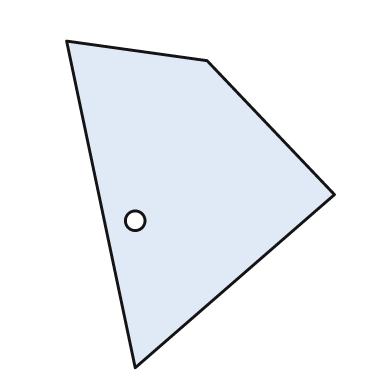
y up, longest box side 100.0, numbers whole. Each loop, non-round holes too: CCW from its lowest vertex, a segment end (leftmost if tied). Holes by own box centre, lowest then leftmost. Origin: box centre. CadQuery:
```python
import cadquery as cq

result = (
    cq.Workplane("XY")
    .moveTo(-20.0, -50.0)
    .lineTo(41.0, 3.0)
    .lineTo(2.0, 44.0)
    .lineTo(-41.0, 50.0)
    .close()
    .moveTo(-20.0, -5.0)
    .circle(3.0)
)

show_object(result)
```